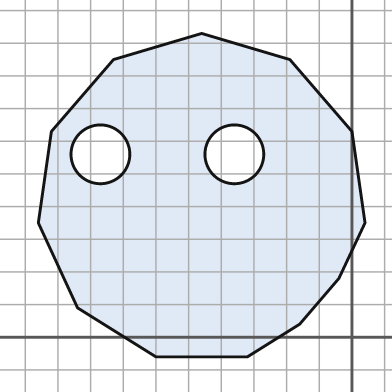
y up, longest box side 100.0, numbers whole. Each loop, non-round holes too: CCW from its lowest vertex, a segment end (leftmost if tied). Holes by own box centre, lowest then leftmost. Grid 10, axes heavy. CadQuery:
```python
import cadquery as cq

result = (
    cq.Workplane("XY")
    .moveTo(-60.0, -6.0)
    .lineTo(-32.0, -6.0)
    .lineTo(-16.0, 4.0)
    .lineTo(-4.0, 18.0)
    .lineTo(4.0, 35.0)
    .lineTo(0.0, 63.0)
    .lineTo(-19.0, 85.0)
    .lineTo(-46.0, 93.0)
    .lineTo(-73.0, 85.0)
    .lineTo(-92.0, 63.0)
    .lineTo(-96.0, 35.0)
    .lineTo(-84.0, 9.0)
    .close()
    .moveTo(-77.0, 56.0)
    .circle(9.0)
    .moveTo(-36.0, 56.0)
    .circle(9.0)
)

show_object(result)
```